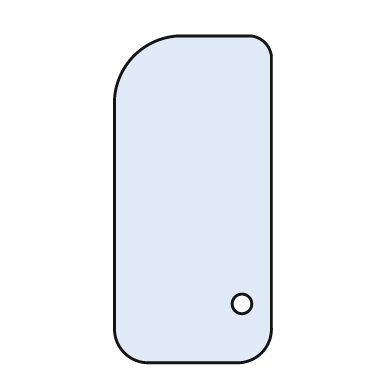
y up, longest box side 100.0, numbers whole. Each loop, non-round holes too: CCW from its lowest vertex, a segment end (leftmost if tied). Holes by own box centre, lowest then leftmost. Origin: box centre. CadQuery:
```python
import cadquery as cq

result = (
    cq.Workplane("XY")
    .moveTo(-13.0, -50.0)
    .lineTo(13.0, -50.0)
    .threePointArc((21.0, -47.0), (24.0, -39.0))
    .lineTo(24.0, 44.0)
    .threePointArc((22.0, 48.0), (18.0, 50.0))
    .lineTo(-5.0, 50.0)
    .threePointArc((-18.0, 44.0), (-24.0, 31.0))
    .lineTo(-24.0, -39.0)
    .threePointArc((-21.0, -47.0), (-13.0, -50.0))
    .close()
    .moveTo(15.0, -32.0)
    .circle(3.0)
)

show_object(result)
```